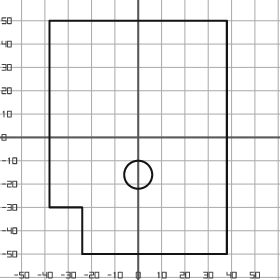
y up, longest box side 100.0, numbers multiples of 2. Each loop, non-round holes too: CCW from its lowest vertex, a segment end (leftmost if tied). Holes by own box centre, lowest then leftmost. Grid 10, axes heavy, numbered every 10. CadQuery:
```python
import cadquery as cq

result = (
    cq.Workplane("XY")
    .moveTo(-24.0, -50.0)
    .lineTo(38.0, -50.0)
    .lineTo(38.0, 50.0)
    .lineTo(-38.0, 50.0)
    .lineTo(-38.0, -30.0)
    .lineTo(-24.0, -30.0)
    .close()
    .moveTo(0.0, -16.0)
    .circle(6.0)
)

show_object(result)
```